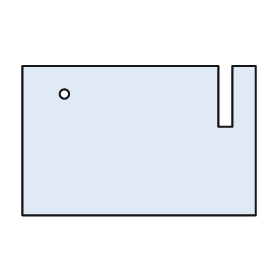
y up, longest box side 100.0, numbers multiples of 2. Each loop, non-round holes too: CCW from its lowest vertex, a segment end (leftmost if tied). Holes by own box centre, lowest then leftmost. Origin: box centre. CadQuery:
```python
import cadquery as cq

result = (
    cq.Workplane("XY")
    .moveTo(-50.0, -32.0)
    .lineTo(50.0, -32.0)
    .lineTo(50.0, 32.0)
    .lineTo(40.0, 32.0)
    .lineTo(40.0, 6.0)
    .lineTo(34.0, 6.0)
    .lineTo(34.0, 32.0)
    .lineTo(-50.0, 32.0)
    .close()
    .moveTo(-32.0, 20.0)
    .circle(2.0)
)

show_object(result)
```